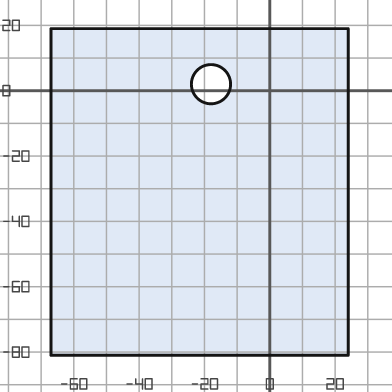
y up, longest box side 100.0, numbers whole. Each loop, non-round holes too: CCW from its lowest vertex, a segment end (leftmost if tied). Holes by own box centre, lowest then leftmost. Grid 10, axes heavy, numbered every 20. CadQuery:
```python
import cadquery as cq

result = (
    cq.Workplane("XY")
    .moveTo(-67.0, -81.0)
    .lineTo(24.0, -81.0)
    .lineTo(24.0, 19.0)
    .lineTo(-67.0, 19.0)
    .close()
    .moveTo(-18.0, 2.0)
    .circle(6.0)
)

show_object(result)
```